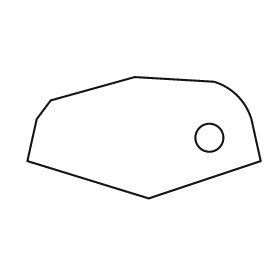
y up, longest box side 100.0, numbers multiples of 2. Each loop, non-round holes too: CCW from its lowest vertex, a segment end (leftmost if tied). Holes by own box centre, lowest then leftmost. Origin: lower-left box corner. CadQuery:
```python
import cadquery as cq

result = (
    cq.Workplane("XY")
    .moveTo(52.0, 0.0)
    .lineTo(100.0, 16.0)
    .lineTo(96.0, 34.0)
    .threePointArc((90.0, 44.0), (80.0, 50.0))
    .lineTo(46.0, 52.0)
    .lineTo(10.0, 42.0)
    .lineTo(4.0, 34.0)
    .lineTo(0.0, 16.0)
    .close()
    .moveTo(78.0, 26.0)
    .circle(6.0)
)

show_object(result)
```